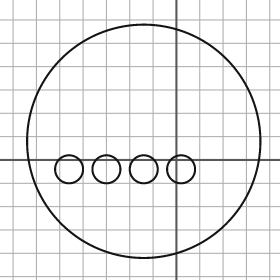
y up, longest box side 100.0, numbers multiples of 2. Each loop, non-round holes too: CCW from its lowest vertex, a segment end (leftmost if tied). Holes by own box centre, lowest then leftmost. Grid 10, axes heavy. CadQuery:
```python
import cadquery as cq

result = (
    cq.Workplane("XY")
    .moveTo(-14.0, 8.0)
    .circle(50.0)
    .moveTo(-46.0, -4.0)
    .circle(6.0)
    .moveTo(-30.0, -4.0)
    .circle(6.0)
    .moveTo(-14.0, -4.0)
    .circle(6.0)
    .moveTo(2.0, -4.0)
    .circle(6.0)
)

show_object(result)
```